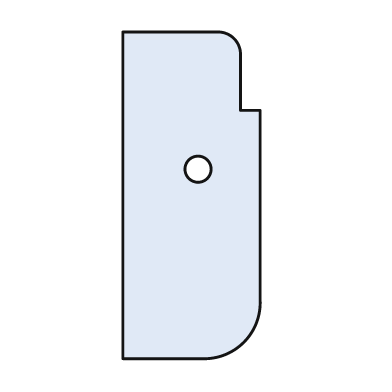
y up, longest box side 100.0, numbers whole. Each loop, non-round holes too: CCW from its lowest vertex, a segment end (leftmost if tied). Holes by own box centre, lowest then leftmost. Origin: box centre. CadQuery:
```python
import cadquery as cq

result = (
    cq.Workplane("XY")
    .moveTo(-21.0, -50.0)
    .lineTo(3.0, -50.0)
    .threePointArc((16.0, -45.0), (21.0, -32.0))
    .lineTo(21.0, 26.0)
    .lineTo(15.0, 26.0)
    .lineTo(15.0, 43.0)
    .threePointArc((13.0, 48.0), (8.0, 50.0))
    .lineTo(-21.0, 50.0)
    .close()
    .moveTo(2.0, 8.0)
    .circle(4.0)
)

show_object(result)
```